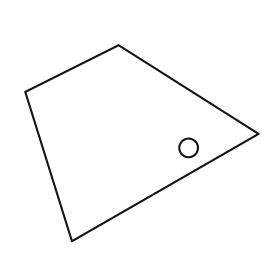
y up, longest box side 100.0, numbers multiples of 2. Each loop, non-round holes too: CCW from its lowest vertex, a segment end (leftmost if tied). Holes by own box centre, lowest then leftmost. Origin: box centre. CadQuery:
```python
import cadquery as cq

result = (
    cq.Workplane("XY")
    .moveTo(-30.0, -42.0)
    .lineTo(50.0, 4.0)
    .lineTo(-10.0, 42.0)
    .lineTo(-50.0, 22.0)
    .close()
    .moveTo(20.0, -2.0)
    .circle(4.0)
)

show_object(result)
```